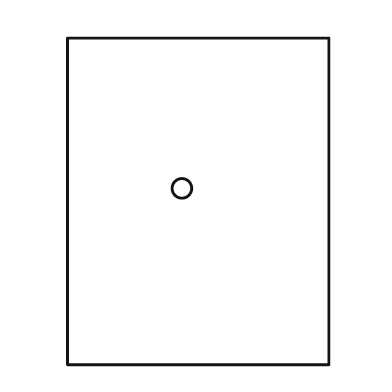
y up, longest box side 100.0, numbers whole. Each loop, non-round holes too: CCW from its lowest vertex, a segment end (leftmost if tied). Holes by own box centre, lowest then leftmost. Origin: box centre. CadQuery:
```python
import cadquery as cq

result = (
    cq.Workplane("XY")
    .moveTo(-40.0, -50.0)
    .lineTo(40.0, -50.0)
    .lineTo(40.0, 50.0)
    .lineTo(-40.0, 50.0)
    .close()
    .moveTo(-5.0, 4.0)
    .circle(3.0)
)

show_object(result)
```